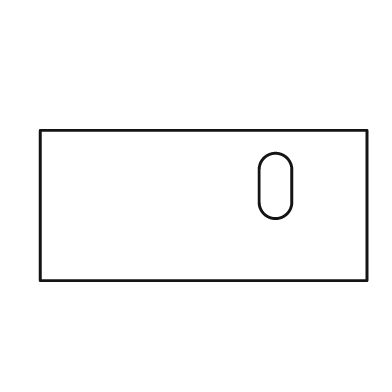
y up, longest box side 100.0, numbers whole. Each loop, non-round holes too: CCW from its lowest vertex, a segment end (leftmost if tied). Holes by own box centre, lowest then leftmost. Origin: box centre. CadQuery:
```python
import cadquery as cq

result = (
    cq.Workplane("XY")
    .moveTo(-50.0, -23.0)
    .lineTo(50.0, -23.0)
    .lineTo(50.0, 23.0)
    .lineTo(-50.0, 23.0)
    .close()
    .moveTo(17.0, 1.0)
    .threePointArc((22.0, -4.0), (27.0, 1.0))
    .lineTo(27.0, 11.0)
    .threePointArc((22.0, 16.0), (17.0, 11.0))
    .close()
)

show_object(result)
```